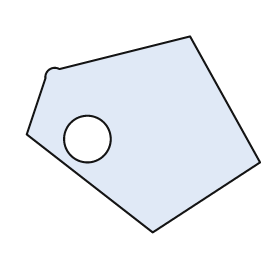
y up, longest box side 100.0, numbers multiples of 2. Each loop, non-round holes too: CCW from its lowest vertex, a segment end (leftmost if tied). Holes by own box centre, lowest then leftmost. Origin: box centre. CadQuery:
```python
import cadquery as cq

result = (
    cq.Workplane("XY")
    .moveTo(4.0, -42.0)
    .lineTo(50.0, -12.0)
    .lineTo(20.0, 42.0)
    .lineTo(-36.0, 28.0)
    .threePointArc((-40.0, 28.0), (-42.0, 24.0))
    .lineTo(-50.0, 0.0)
    .close()
    .moveTo(-24.0, -2.0)
    .circle(10.0)
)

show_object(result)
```